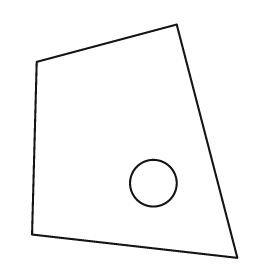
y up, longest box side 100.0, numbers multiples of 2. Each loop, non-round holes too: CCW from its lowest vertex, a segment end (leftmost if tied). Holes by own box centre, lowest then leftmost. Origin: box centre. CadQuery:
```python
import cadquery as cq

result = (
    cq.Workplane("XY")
    .moveTo(44.0, -50.0)
    .lineTo(18.0, 50.0)
    .lineTo(-42.0, 34.0)
    .lineTo(-44.0, -40.0)
    .close()
    .moveTo(8.0, -18.0)
    .circle(10.0)
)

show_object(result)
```